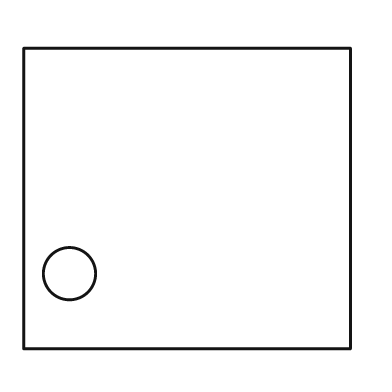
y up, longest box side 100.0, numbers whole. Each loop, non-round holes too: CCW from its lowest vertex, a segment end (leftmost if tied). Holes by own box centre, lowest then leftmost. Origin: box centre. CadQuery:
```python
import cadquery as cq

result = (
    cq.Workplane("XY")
    .moveTo(-50.0, -46.0)
    .lineTo(50.0, -46.0)
    .lineTo(50.0, 46.0)
    .lineTo(-50.0, 46.0)
    .close()
    .moveTo(-36.0, -23.0)
    .circle(8.0)
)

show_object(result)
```